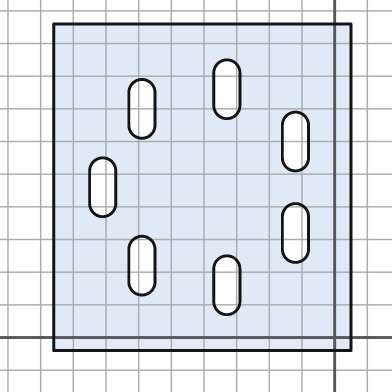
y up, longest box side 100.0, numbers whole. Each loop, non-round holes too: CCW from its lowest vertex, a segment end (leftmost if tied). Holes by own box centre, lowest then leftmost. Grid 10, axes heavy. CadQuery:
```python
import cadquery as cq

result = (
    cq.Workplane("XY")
    .moveTo(-86.0, -4.0)
    .lineTo(5.0, -4.0)
    .lineTo(5.0, 96.0)
    .lineTo(-86.0, 96.0)
    .close()
    .moveTo(-37.0, 11.0)
    .threePointArc((-33.0, 7.0), (-29.0, 11.0))
    .lineTo(-29.0, 21.0)
    .threePointArc((-33.0, 25.0), (-37.0, 21.0))
    .close()
    .moveTo(-63.0, 17.0)
    .threePointArc((-59.0, 13.0), (-55.0, 17.0))
    .lineTo(-55.0, 27.0)
    .threePointArc((-59.0, 31.0), (-63.0, 27.0))
    .close()
    .moveTo(-16.0, 27.0)
    .threePointArc((-12.0, 23.0), (-8.0, 27.0))
    .lineTo(-8.0, 37.0)
    .threePointArc((-12.0, 41.0), (-16.0, 37.0))
    .close()
    .moveTo(-75.0, 41.0)
    .threePointArc((-71.0, 37.0), (-67.0, 41.0))
    .lineTo(-67.0, 51.0)
    .threePointArc((-71.0, 55.0), (-75.0, 51.0))
    .close()
    .moveTo(-16.0, 55.0)
    .threePointArc((-12.0, 51.0), (-8.0, 55.0))
    .lineTo(-8.0, 65.0)
    .threePointArc((-12.0, 69.0), (-16.0, 65.0))
    .close()
    .moveTo(-63.0, 65.0)
    .threePointArc((-59.0, 61.0), (-55.0, 65.0))
    .lineTo(-55.0, 75.0)
    .threePointArc((-59.0, 79.0), (-63.0, 75.0))
    .close()
    .moveTo(-37.0, 71.0)
    .threePointArc((-33.0, 67.0), (-29.0, 71.0))
    .lineTo(-29.0, 81.0)
    .threePointArc((-33.0, 85.0), (-37.0, 81.0))
    .close()
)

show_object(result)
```